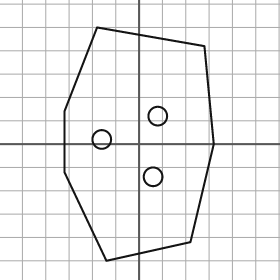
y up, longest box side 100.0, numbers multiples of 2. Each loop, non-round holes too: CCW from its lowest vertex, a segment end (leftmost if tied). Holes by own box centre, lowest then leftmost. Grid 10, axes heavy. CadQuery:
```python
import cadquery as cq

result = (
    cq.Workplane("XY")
    .moveTo(-14.0, -50.0)
    .lineTo(22.0, -42.0)
    .lineTo(32.0, 0.0)
    .lineTo(28.0, 42.0)
    .lineTo(-18.0, 50.0)
    .lineTo(-32.0, 14.0)
    .lineTo(-32.0, -12.0)
    .close()
    .moveTo(6.0, -14.0)
    .circle(4.0)
    .moveTo(-16.0, 2.0)
    .circle(4.0)
    .moveTo(8.0, 12.0)
    .circle(4.0)
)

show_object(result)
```